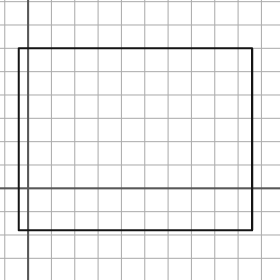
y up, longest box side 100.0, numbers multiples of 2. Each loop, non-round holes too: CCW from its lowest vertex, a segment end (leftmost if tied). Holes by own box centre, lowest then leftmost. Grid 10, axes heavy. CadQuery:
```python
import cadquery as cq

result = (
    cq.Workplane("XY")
    .moveTo(-4.0, -18.0)
    .lineTo(96.0, -18.0)
    .lineTo(96.0, 60.0)
    .lineTo(-4.0, 60.0)
    .close()
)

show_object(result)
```